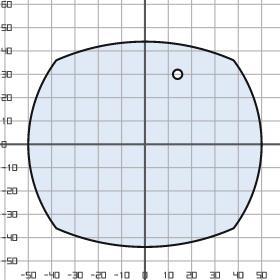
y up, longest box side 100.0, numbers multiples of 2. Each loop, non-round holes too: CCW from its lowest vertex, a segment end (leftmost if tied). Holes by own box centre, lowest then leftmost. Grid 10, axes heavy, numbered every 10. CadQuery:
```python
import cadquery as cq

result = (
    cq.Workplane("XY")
    .moveTo(-38.0, -36.0)
    .threePointArc((0.0, -44.0), (38.0, -36.0))
    .threePointArc((50.0, 0.0), (38.0, 36.0))
    .threePointArc((0.0, 44.0), (-38.0, 36.0))
    .threePointArc((-50.0, 0.0), (-38.0, -36.0))
    .close()
    .moveTo(14.0, 30.0)
    .circle(2.0)
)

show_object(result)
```